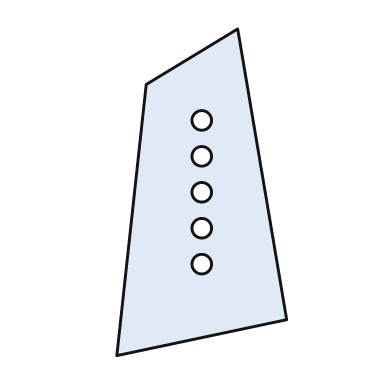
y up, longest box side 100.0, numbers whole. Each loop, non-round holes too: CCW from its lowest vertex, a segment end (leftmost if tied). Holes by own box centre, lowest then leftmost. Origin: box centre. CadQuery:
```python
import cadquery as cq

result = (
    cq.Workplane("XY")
    .moveTo(-26.0, -50.0)
    .lineTo(26.0, -39.0)
    .lineTo(11.0, 50.0)
    .lineTo(-17.0, 33.0)
    .close()
    .moveTo(0.0, -22.0)
    .circle(3.0)
    .moveTo(0.0, -11.0)
    .circle(3.0)
    .moveTo(0.0, 0.0)
    .circle(3.0)
    .moveTo(0.0, 11.0)
    .circle(3.0)
    .moveTo(0.0, 22.0)
    .circle(3.0)
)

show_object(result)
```